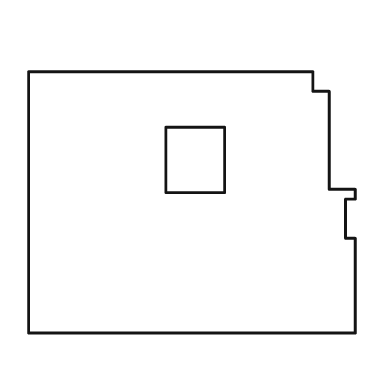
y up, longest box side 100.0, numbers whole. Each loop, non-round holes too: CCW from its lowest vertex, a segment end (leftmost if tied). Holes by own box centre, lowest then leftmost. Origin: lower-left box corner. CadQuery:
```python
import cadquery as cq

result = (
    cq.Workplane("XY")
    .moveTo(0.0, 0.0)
    .lineTo(100.0, 0.0)
    .lineTo(100.0, 29.0)
    .lineTo(97.0, 29.0)
    .lineTo(97.0, 41.0)
    .lineTo(100.0, 41.0)
    .lineTo(100.0, 44.0)
    .lineTo(92.0, 44.0)
    .lineTo(92.0, 74.0)
    .lineTo(87.0, 74.0)
    .lineTo(87.0, 80.0)
    .lineTo(0.0, 80.0)
    .close()
    .moveTo(42.0, 43.0)
    .lineTo(60.0, 43.0)
    .lineTo(60.0, 63.0)
    .lineTo(42.0, 63.0)
    .close()
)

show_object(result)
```